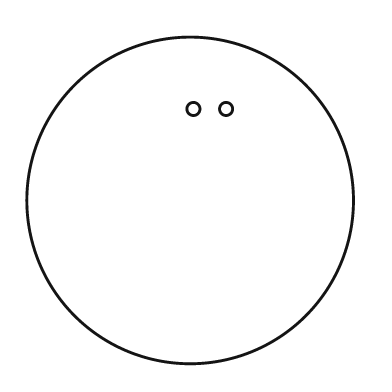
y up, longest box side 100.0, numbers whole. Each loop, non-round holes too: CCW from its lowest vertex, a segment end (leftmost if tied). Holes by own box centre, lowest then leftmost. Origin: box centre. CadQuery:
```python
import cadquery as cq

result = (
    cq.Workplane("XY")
    .moveTo(0.0, 0.0)
    .circle(50.0)
    .moveTo(1.0, 28.0)
    .circle(2.0)
    .moveTo(11.0, 28.0)
    .circle(2.0)
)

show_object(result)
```